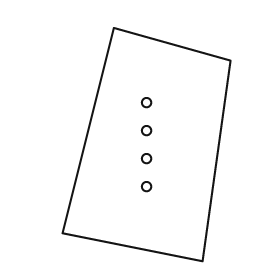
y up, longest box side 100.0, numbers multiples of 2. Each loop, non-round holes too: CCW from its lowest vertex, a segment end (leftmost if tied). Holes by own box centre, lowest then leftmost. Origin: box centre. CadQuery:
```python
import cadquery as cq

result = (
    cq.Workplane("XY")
    .moveTo(24.0, -50.0)
    .lineTo(36.0, 36.0)
    .lineTo(-14.0, 50.0)
    .lineTo(-36.0, -38.0)
    .close()
    .moveTo(0.0, -18.0)
    .circle(2.0)
    .moveTo(0.0, -6.0)
    .circle(2.0)
    .moveTo(0.0, 6.0)
    .circle(2.0)
    .moveTo(0.0, 18.0)
    .circle(2.0)
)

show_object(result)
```